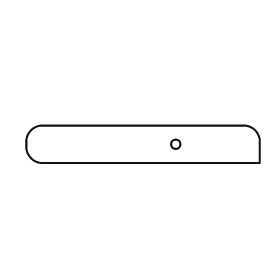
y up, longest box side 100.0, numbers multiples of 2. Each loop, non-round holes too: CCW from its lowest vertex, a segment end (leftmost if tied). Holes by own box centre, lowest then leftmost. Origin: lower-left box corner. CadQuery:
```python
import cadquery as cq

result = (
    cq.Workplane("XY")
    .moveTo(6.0, 0.0)
    .lineTo(100.0, 0.0)
    .lineTo(100.0, 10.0)
    .threePointArc((98.0, 14.0), (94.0, 16.0))
    .lineTo(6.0, 16.0)
    .threePointArc((2.0, 14.0), (0.0, 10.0))
    .lineTo(0.0, 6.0)
    .threePointArc((2.0, 2.0), (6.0, 0.0))
    .close()
    .moveTo(64.0, 8.0)
    .circle(2.0)
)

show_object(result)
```